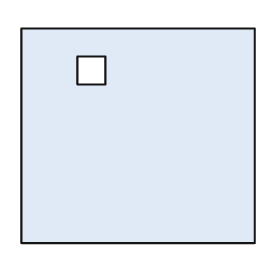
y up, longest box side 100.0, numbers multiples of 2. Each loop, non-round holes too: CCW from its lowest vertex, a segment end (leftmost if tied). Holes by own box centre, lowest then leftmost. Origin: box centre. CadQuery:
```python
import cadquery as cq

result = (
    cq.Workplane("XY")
    .moveTo(-50.0, -46.0)
    .lineTo(50.0, -46.0)
    .lineTo(50.0, 46.0)
    .lineTo(-50.0, 46.0)
    .close()
    .moveTo(-26.0, 22.0)
    .lineTo(-14.0, 22.0)
    .lineTo(-14.0, 34.0)
    .lineTo(-26.0, 34.0)
    .close()
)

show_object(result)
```